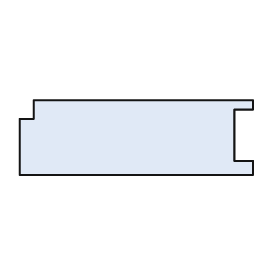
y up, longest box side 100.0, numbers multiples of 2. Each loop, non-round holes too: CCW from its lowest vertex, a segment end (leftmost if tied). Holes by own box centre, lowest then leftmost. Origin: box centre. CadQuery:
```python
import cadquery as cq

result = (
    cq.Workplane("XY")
    .moveTo(-50.0, -16.0)
    .lineTo(50.0, -16.0)
    .lineTo(50.0, -10.0)
    .lineTo(42.0, -10.0)
    .lineTo(42.0, 12.0)
    .lineTo(50.0, 12.0)
    .lineTo(50.0, 16.0)
    .lineTo(-44.0, 16.0)
    .lineTo(-44.0, 8.0)
    .lineTo(-50.0, 8.0)
    .close()
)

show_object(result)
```